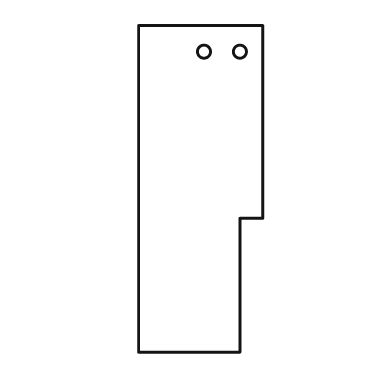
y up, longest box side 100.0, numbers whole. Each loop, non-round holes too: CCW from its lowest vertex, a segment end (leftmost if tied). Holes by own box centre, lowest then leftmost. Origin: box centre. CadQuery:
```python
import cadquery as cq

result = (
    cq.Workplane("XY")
    .moveTo(-19.0, -50.0)
    .lineTo(12.0, -50.0)
    .lineTo(12.0, -9.0)
    .lineTo(19.0, -9.0)
    .lineTo(19.0, 50.0)
    .lineTo(-19.0, 50.0)
    .close()
    .moveTo(1.0, 42.0)
    .circle(2.0)
    .moveTo(12.0, 42.0)
    .circle(2.0)
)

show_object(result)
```